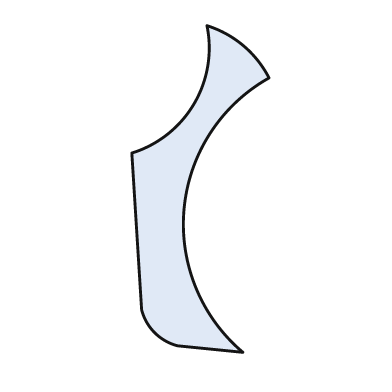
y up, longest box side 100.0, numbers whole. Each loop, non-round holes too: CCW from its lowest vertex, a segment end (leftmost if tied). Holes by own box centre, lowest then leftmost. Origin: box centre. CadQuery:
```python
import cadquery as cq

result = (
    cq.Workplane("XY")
    .moveTo(13.0, -50.0)
    .threePointArc((-5.0, -6.0), (21.0, 34.0))
    .threePointArc((13.0, 44.0), (2.0, 50.0))
    .threePointArc((-2.0, 26.0), (-21.0, 11.0))
    .lineTo(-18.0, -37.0)
    .threePointArc((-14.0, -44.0), (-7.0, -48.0))
    .close()
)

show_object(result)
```